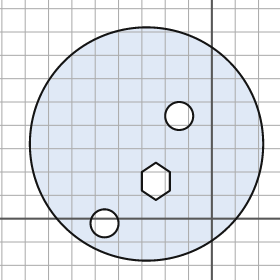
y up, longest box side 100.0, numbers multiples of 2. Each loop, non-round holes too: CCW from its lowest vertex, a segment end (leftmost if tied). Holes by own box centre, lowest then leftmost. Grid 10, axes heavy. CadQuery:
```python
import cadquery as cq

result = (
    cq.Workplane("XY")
    .moveTo(-28.0, 32.0)
    .circle(50.0)
    .moveTo(-46.0, -2.0)
    .circle(6.0)
    .moveTo(-24.0, 8.0)
    .lineTo(-18.0, 12.0)
    .lineTo(-18.0, 20.0)
    .lineTo(-24.0, 24.0)
    .lineTo(-30.0, 20.0)
    .lineTo(-30.0, 12.0)
    .close()
    .moveTo(-14.0, 44.0)
    .circle(6.0)
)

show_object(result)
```